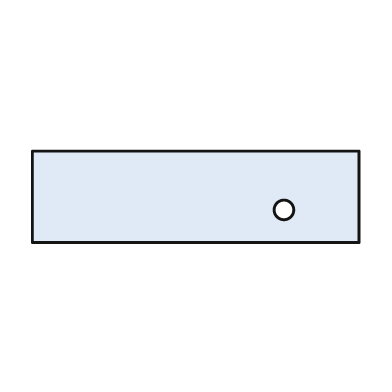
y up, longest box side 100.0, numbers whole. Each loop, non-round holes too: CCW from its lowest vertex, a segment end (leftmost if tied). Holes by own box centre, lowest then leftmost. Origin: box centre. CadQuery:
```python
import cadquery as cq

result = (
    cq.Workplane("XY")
    .moveTo(-50.0, -14.0)
    .lineTo(50.0, -14.0)
    .lineTo(50.0, 14.0)
    .lineTo(-50.0, 14.0)
    .close()
    .moveTo(27.0, -4.0)
    .circle(3.0)
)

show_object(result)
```